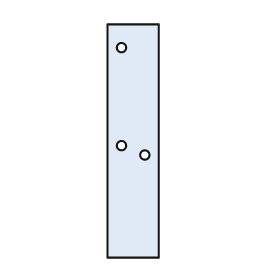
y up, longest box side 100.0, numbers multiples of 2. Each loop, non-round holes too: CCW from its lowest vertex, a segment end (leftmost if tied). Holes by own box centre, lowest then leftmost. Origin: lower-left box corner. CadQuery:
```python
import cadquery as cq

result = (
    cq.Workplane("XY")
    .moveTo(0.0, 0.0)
    .lineTo(22.0, 0.0)
    .lineTo(22.0, 100.0)
    .lineTo(0.0, 100.0)
    .close()
    .moveTo(16.0, 44.0)
    .circle(2.0)
    .moveTo(6.0, 48.0)
    .circle(2.0)
    .moveTo(6.0, 90.0)
    .circle(2.0)
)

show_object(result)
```